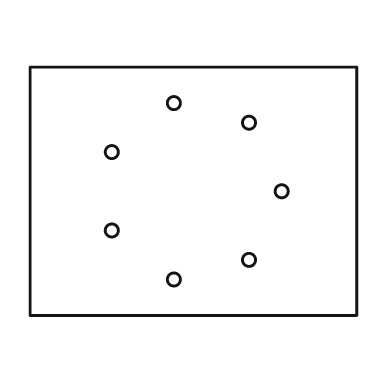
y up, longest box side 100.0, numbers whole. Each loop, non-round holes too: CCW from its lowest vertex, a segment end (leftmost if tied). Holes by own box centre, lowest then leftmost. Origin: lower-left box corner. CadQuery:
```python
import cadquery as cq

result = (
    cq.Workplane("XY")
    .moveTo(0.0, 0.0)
    .lineTo(100.0, 0.0)
    .lineTo(100.0, 76.0)
    .lineTo(0.0, 76.0)
    .close()
    .moveTo(44.0, 11.0)
    .circle(2.0)
    .moveTo(67.0, 17.0)
    .circle(2.0)
    .moveTo(25.0, 26.0)
    .circle(2.0)
    .moveTo(77.0, 38.0)
    .circle(2.0)
    .moveTo(25.0, 50.0)
    .circle(2.0)
    .moveTo(67.0, 59.0)
    .circle(2.0)
    .moveTo(44.0, 65.0)
    .circle(2.0)
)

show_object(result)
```